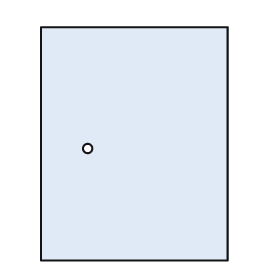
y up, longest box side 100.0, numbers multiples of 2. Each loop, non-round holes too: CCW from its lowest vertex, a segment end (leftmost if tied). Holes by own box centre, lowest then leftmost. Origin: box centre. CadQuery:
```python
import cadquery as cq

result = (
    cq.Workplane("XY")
    .moveTo(-40.0, -50.0)
    .lineTo(40.0, -50.0)
    .lineTo(40.0, 50.0)
    .lineTo(-40.0, 50.0)
    .close()
    .moveTo(-20.0, -2.0)
    .circle(2.0)
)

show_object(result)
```